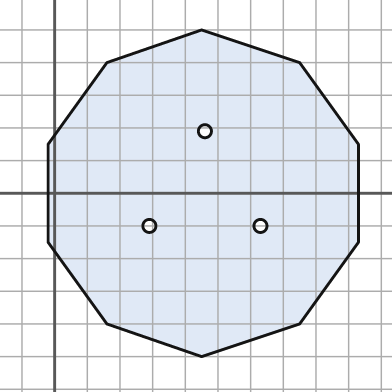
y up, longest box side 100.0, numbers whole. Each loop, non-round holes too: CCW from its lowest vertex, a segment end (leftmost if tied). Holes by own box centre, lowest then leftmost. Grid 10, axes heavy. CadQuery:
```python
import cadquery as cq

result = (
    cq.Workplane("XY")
    .moveTo(45.0, -50.0)
    .lineTo(75.0, -40.0)
    .lineTo(93.0, -15.0)
    .lineTo(93.0, 15.0)
    .lineTo(75.0, 40.0)
    .lineTo(45.0, 50.0)
    .lineTo(16.0, 40.0)
    .lineTo(-2.0, 15.0)
    .lineTo(-2.0, -15.0)
    .lineTo(16.0, -40.0)
    .close()
    .moveTo(29.0, -10.0)
    .circle(2.0)
    .moveTo(63.0, -10.0)
    .circle(2.0)
    .moveTo(46.0, 19.0)
    .circle(2.0)
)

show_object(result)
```